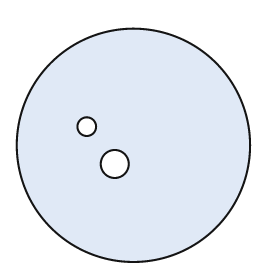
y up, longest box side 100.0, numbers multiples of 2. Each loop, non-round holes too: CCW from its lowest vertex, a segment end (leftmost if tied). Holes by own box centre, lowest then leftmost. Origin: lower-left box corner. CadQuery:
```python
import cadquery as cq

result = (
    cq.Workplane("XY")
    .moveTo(50.0, 50.0)
    .circle(50.0)
    .moveTo(42.0, 42.0)
    .circle(6.0)
    .moveTo(30.0, 58.0)
    .circle(4.0)
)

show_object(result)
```